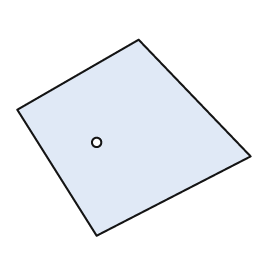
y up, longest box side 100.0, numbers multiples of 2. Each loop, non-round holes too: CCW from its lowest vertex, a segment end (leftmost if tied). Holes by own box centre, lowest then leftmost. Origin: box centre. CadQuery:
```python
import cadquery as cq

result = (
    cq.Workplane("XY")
    .moveTo(-16.0, -42.0)
    .lineTo(50.0, -8.0)
    .lineTo(2.0, 42.0)
    .lineTo(-50.0, 12.0)
    .close()
    .moveTo(-16.0, -2.0)
    .circle(2.0)
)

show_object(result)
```